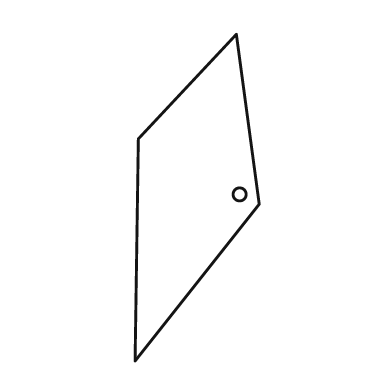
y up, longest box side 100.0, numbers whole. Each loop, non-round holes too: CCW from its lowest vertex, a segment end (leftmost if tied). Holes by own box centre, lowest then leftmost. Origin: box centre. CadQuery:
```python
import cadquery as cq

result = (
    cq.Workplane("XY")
    .moveTo(-19.0, -50.0)
    .lineTo(19.0, -2.0)
    .lineTo(12.0, 50.0)
    .lineTo(-18.0, 18.0)
    .close()
    .moveTo(13.0, 1.0)
    .circle(2.0)
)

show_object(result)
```